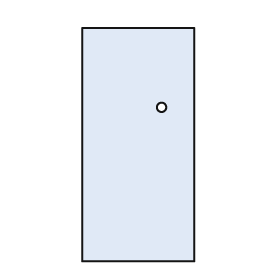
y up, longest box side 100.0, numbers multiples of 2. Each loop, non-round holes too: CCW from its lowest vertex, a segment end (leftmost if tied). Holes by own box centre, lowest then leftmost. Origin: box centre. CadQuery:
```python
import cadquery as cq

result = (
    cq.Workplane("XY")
    .moveTo(-24.0, -50.0)
    .lineTo(24.0, -50.0)
    .lineTo(24.0, 50.0)
    .lineTo(-24.0, 50.0)
    .close()
    .moveTo(10.0, 16.0)
    .circle(2.0)
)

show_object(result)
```